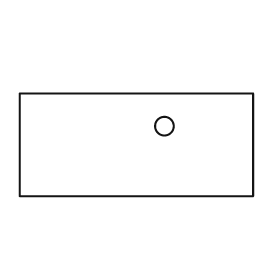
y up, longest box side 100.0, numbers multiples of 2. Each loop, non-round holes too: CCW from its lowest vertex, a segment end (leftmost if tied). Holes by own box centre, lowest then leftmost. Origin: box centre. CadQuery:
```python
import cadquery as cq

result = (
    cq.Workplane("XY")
    .moveTo(-50.0, -22.0)
    .lineTo(50.0, -22.0)
    .lineTo(50.0, 22.0)
    .lineTo(-50.0, 22.0)
    .close()
    .moveTo(12.0, 8.0)
    .circle(4.0)
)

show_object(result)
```